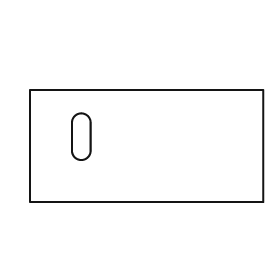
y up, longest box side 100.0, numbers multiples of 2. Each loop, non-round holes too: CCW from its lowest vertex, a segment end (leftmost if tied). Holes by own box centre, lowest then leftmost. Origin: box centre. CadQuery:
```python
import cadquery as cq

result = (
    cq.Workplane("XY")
    .moveTo(-50.0, -24.0)
    .lineTo(50.0, -24.0)
    .lineTo(50.0, 24.0)
    .lineTo(-50.0, 24.0)
    .close()
    .moveTo(-32.0, -2.0)
    .threePointArc((-28.0, -6.0), (-24.0, -2.0))
    .lineTo(-24.0, 10.0)
    .threePointArc((-28.0, 14.0), (-32.0, 10.0))
    .close()
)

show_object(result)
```